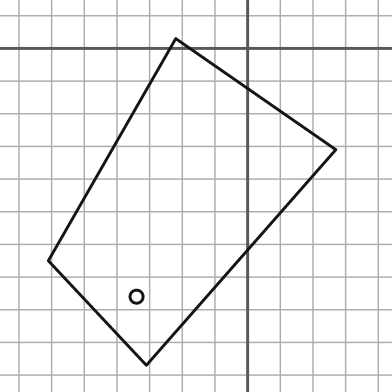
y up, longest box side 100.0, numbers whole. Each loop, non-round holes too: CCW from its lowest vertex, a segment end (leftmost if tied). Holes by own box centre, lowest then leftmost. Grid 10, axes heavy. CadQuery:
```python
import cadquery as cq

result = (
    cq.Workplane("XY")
    .moveTo(-31.0, -97.0)
    .lineTo(27.0, -31.0)
    .lineTo(-22.0, 3.0)
    .lineTo(-61.0, -65.0)
    .close()
    .moveTo(-34.0, -76.0)
    .circle(2.0)
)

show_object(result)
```